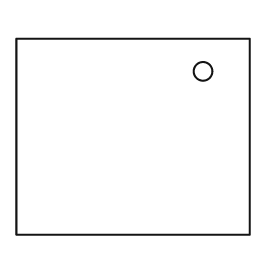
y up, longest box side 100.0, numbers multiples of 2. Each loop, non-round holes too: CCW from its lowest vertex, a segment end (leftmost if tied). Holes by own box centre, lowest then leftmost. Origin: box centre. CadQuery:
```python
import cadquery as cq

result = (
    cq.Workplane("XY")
    .moveTo(-50.0, -42.0)
    .lineTo(50.0, -42.0)
    .lineTo(50.0, 42.0)
    .lineTo(-50.0, 42.0)
    .close()
    .moveTo(30.0, 28.0)
    .circle(4.0)
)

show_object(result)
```